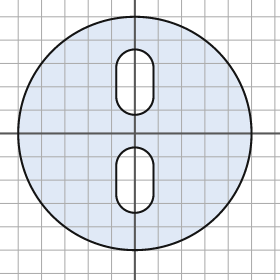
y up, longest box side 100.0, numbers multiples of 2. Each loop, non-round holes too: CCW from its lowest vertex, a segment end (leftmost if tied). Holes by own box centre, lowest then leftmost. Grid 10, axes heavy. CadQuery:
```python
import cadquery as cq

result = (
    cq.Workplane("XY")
    .moveTo(0.0, 0.0)
    .circle(50.0)
    .moveTo(-8.0, -26.0)
    .threePointArc((0.0, -34.0), (8.0, -26.0))
    .lineTo(8.0, -14.0)
    .threePointArc((0.0, -6.0), (-8.0, -14.0))
    .close()
    .moveTo(-8.0, 16.0)
    .threePointArc((0.0, 8.0), (8.0, 16.0))
    .lineTo(8.0, 28.0)
    .threePointArc((0.0, 36.0), (-8.0, 28.0))
    .close()
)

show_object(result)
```